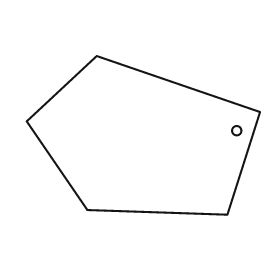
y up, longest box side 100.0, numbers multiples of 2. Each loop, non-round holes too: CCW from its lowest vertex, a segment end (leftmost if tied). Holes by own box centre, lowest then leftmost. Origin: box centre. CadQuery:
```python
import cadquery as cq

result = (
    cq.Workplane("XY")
    .moveTo(36.0, -34.0)
    .lineTo(50.0, 10.0)
    .lineTo(-20.0, 34.0)
    .lineTo(-50.0, 6.0)
    .lineTo(-24.0, -32.0)
    .close()
    .moveTo(40.0, 2.0)
    .circle(2.0)
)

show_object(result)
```